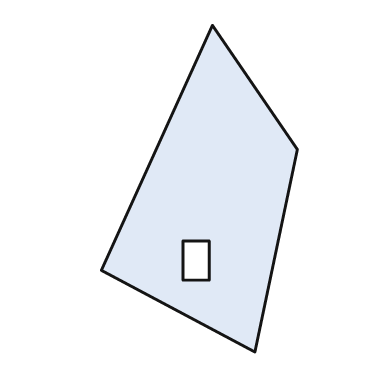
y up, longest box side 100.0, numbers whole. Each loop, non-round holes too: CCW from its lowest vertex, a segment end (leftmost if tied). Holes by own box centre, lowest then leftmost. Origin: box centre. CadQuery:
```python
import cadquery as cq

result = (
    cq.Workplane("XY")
    .moveTo(17.0, -50.0)
    .lineTo(30.0, 12.0)
    .lineTo(4.0, 50.0)
    .lineTo(-30.0, -25.0)
    .close()
    .moveTo(-5.0, -28.0)
    .lineTo(3.0, -28.0)
    .lineTo(3.0, -16.0)
    .lineTo(-5.0, -16.0)
    .close()
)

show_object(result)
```